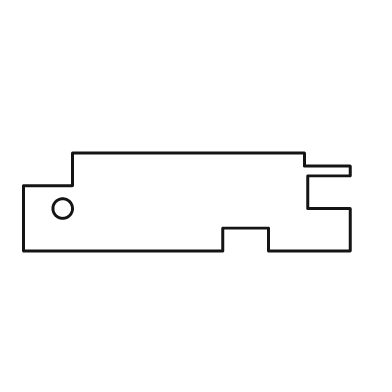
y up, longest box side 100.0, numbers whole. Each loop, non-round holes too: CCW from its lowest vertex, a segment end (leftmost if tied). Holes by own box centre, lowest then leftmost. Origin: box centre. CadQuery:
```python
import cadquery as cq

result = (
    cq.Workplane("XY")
    .moveTo(-50.0, -15.0)
    .lineTo(11.0, -15.0)
    .lineTo(11.0, -8.0)
    .lineTo(25.0, -8.0)
    .lineTo(25.0, -15.0)
    .lineTo(50.0, -15.0)
    .lineTo(50.0, -2.0)
    .lineTo(37.0, -2.0)
    .lineTo(37.0, 8.0)
    .lineTo(50.0, 8.0)
    .lineTo(50.0, 11.0)
    .lineTo(36.0, 11.0)
    .lineTo(36.0, 15.0)
    .lineTo(-35.0, 15.0)
    .lineTo(-35.0, 5.0)
    .lineTo(-50.0, 5.0)
    .close()
    .moveTo(-38.0, -2.0)
    .circle(3.0)
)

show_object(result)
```